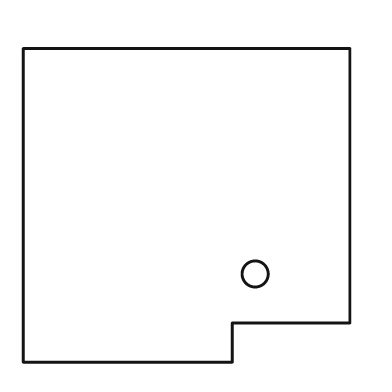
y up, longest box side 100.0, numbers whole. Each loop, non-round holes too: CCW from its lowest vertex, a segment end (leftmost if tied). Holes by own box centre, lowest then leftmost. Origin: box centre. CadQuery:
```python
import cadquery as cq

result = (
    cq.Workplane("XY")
    .moveTo(-50.0, -48.0)
    .lineTo(14.0, -48.0)
    .lineTo(14.0, -36.0)
    .lineTo(50.0, -36.0)
    .lineTo(50.0, 48.0)
    .lineTo(-50.0, 48.0)
    .close()
    .moveTo(21.0, -21.0)
    .circle(4.0)
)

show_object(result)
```